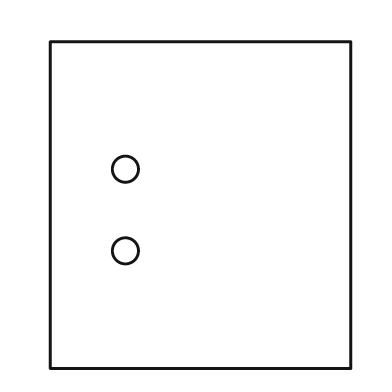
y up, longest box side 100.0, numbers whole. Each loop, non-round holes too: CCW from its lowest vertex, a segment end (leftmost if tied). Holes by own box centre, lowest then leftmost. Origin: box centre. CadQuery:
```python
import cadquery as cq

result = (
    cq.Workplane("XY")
    .moveTo(-46.0, -50.0)
    .lineTo(46.0, -50.0)
    .lineTo(46.0, 50.0)
    .lineTo(-46.0, 50.0)
    .close()
    .moveTo(-23.0, -14.0)
    .circle(4.0)
    .moveTo(-23.0, 11.0)
    .circle(4.0)
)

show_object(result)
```